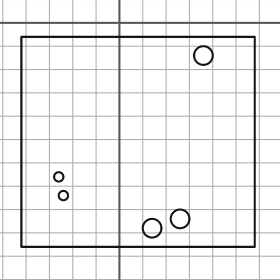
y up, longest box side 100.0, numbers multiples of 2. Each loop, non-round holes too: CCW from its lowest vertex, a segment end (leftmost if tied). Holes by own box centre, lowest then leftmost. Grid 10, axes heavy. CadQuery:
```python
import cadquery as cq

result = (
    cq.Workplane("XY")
    .moveTo(-42.0, -96.0)
    .lineTo(58.0, -96.0)
    .lineTo(58.0, -6.0)
    .lineTo(-42.0, -6.0)
    .close()
    .moveTo(14.0, -88.0)
    .circle(4.0)
    .moveTo(26.0, -84.0)
    .circle(4.0)
    .moveTo(-24.0, -74.0)
    .circle(2.0)
    .moveTo(-26.0, -66.0)
    .circle(2.0)
    .moveTo(36.0, -14.0)
    .circle(4.0)
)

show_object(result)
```